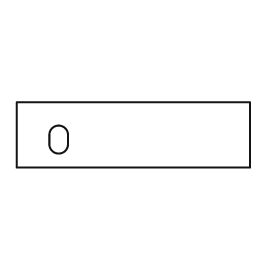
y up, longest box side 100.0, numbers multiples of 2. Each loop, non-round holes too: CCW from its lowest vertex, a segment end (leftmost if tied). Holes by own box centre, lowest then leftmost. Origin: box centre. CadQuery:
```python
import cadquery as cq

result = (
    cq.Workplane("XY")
    .moveTo(-50.0, -14.0)
    .lineTo(50.0, -14.0)
    .lineTo(50.0, 14.0)
    .lineTo(-50.0, 14.0)
    .close()
    .moveTo(-36.0, -4.0)
    .threePointArc((-32.0, -8.0), (-28.0, -4.0))
    .lineTo(-28.0, 0.0)
    .threePointArc((-32.0, 4.0), (-36.0, 0.0))
    .close()
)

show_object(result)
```